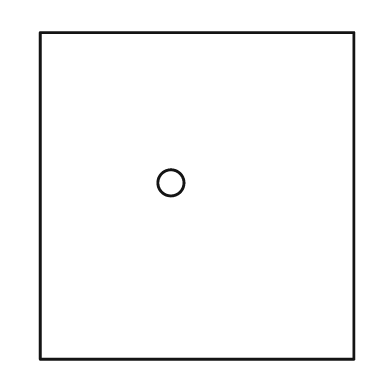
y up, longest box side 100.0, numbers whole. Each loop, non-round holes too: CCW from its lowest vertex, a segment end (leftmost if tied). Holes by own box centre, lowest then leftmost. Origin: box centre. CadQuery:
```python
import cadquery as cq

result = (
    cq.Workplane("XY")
    .moveTo(-48.0, -50.0)
    .lineTo(48.0, -50.0)
    .lineTo(48.0, 50.0)
    .lineTo(-48.0, 50.0)
    .close()
    .moveTo(-8.0, 4.0)
    .circle(4.0)
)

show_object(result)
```